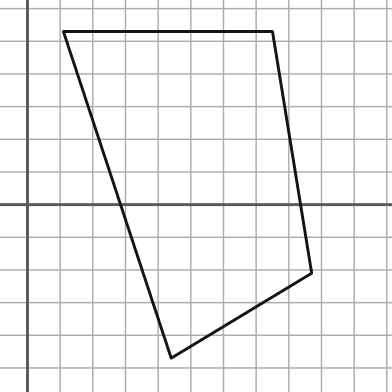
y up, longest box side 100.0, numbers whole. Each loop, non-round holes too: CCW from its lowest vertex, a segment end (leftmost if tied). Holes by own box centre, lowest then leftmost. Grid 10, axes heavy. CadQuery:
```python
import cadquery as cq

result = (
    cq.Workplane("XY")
    .moveTo(44.0, -47.0)
    .lineTo(87.0, -21.0)
    .lineTo(75.0, 53.0)
    .lineTo(11.0, 53.0)
    .close()
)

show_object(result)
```